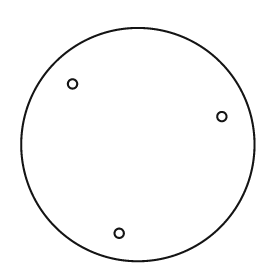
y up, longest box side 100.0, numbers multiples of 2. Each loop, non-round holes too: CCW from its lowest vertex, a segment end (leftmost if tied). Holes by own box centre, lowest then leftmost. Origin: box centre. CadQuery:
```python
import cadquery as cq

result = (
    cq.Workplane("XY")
    .moveTo(0.0, 0.0)
    .circle(50.0)
    .moveTo(-8.0, -38.0)
    .circle(2.0)
    .moveTo(36.0, 12.0)
    .circle(2.0)
    .moveTo(-28.0, 26.0)
    .circle(2.0)
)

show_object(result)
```